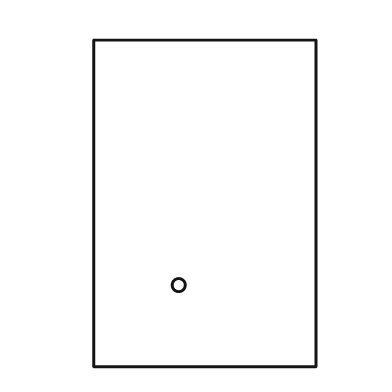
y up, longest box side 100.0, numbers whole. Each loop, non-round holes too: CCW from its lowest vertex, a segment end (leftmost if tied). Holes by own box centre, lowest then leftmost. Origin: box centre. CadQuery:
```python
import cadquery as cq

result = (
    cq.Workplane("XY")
    .moveTo(-34.0, -50.0)
    .lineTo(34.0, -50.0)
    .lineTo(34.0, 50.0)
    .lineTo(-34.0, 50.0)
    .close()
    .moveTo(-8.0, -25.0)
    .circle(2.0)
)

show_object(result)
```